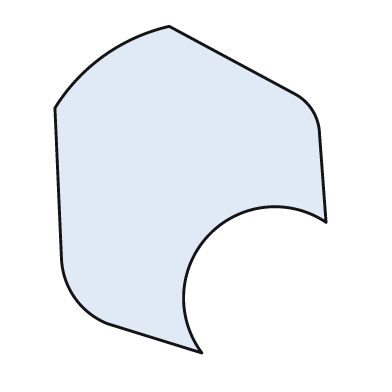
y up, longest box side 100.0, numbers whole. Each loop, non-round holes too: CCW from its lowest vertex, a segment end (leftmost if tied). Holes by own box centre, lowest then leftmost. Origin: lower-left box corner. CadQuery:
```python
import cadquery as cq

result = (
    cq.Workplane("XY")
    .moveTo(45.0, 0.0)
    .threePointArc((47.0, 36.0), (83.0, 40.0))
    .lineTo(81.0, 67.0)
    .threePointArc((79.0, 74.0), (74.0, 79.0))
    .lineTo(35.0, 100.0)
    .threePointArc((15.0, 91.0), (0.0, 75.0))
    .lineTo(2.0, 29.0)
    .threePointArc((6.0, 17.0), (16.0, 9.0))
    .close()
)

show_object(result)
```